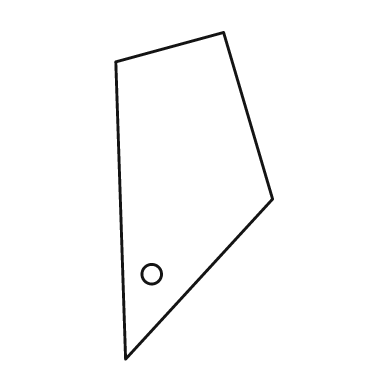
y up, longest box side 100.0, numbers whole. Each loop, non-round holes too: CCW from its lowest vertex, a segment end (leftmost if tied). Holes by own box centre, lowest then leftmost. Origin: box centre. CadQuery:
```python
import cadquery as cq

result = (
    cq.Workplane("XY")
    .moveTo(-21.0, -50.0)
    .lineTo(24.0, -1.0)
    .lineTo(9.0, 50.0)
    .lineTo(-24.0, 41.0)
    .close()
    .moveTo(-13.0, -24.0)
    .circle(3.0)
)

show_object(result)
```